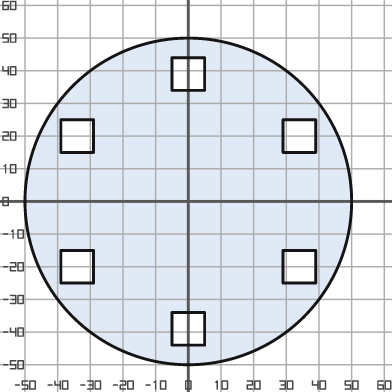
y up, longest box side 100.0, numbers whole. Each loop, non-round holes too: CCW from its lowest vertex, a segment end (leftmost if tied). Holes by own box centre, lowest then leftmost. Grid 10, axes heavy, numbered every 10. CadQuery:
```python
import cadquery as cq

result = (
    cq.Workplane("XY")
    .moveTo(0.0, 0.0)
    .circle(50.0)
    .moveTo(-5.0, -44.0)
    .lineTo(5.0, -44.0)
    .lineTo(5.0, -34.0)
    .lineTo(-5.0, -34.0)
    .close()
    .moveTo(-39.0, -25.0)
    .lineTo(-29.0, -25.0)
    .lineTo(-29.0, -15.0)
    .lineTo(-39.0, -15.0)
    .close()
    .moveTo(29.0, -25.0)
    .lineTo(39.0, -25.0)
    .lineTo(39.0, -15.0)
    .lineTo(29.0, -15.0)
    .close()
    .moveTo(-39.0, 15.0)
    .lineTo(-29.0, 15.0)
    .lineTo(-29.0, 25.0)
    .lineTo(-39.0, 25.0)
    .close()
    .moveTo(29.0, 15.0)
    .lineTo(39.0, 15.0)
    .lineTo(39.0, 25.0)
    .lineTo(29.0, 25.0)
    .close()
    .moveTo(-5.0, 34.0)
    .lineTo(5.0, 34.0)
    .lineTo(5.0, 44.0)
    .lineTo(-5.0, 44.0)
    .close()
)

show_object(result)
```